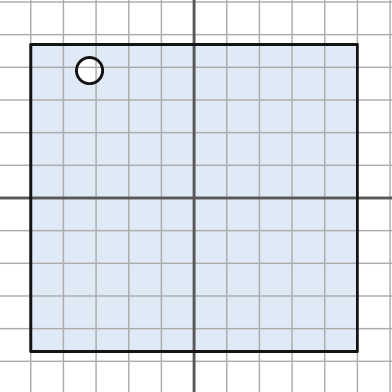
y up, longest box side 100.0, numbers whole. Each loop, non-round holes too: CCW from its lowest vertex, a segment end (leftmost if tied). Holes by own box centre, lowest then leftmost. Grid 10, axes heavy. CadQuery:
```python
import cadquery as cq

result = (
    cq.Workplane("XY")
    .moveTo(-50.0, -47.0)
    .lineTo(50.0, -47.0)
    .lineTo(50.0, 47.0)
    .lineTo(-50.0, 47.0)
    .close()
    .moveTo(-32.0, 39.0)
    .circle(4.0)
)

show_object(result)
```